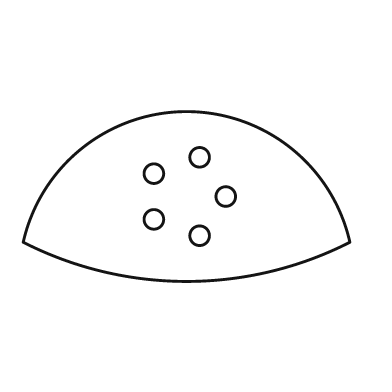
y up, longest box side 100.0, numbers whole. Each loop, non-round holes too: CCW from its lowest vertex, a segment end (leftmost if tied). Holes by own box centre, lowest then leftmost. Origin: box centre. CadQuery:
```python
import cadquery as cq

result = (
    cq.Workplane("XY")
    .moveTo(-50.0, -14.0)
    .threePointArc((0.0, -26.0), (50.0, -14.0))
    .threePointArc((0.0, 26.0), (-50.0, -14.0))
    .close()
    .moveTo(4.0, -12.0)
    .circle(3.0)
    .moveTo(-10.0, -7.0)
    .circle(3.0)
    .moveTo(12.0, 0.0)
    .circle(3.0)
    .moveTo(-10.0, 7.0)
    .circle(3.0)
    .moveTo(4.0, 12.0)
    .circle(3.0)
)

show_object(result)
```